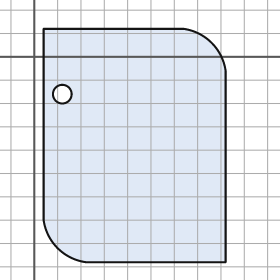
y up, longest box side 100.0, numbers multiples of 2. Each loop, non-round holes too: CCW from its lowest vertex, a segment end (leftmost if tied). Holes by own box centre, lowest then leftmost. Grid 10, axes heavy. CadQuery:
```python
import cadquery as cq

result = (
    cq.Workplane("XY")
    .moveTo(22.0, -88.0)
    .lineTo(82.0, -88.0)
    .lineTo(82.0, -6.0)
    .threePointArc((76.0, 6.0), (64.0, 12.0))
    .lineTo(4.0, 12.0)
    .lineTo(4.0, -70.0)
    .threePointArc((10.0, -82.0), (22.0, -88.0))
    .close()
    .moveTo(12.0, -16.0)
    .circle(4.0)
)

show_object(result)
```